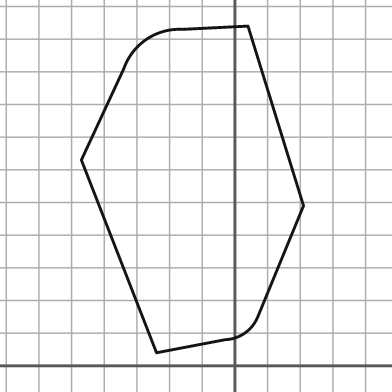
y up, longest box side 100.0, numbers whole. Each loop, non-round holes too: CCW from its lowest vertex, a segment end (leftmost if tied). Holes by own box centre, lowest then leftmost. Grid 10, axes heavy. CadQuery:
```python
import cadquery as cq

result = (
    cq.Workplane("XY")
    .moveTo(-24.0, 4.0)
    .lineTo(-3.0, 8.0)
    .threePointArc((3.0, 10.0), (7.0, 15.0))
    .lineTo(21.0, 49.0)
    .lineTo(4.0, 104.0)
    .lineTo(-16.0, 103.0)
    .threePointArc((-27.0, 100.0), (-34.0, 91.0))
    .lineTo(-47.0, 63.0)
    .close()
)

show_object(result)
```